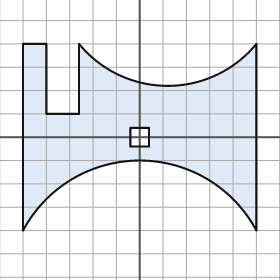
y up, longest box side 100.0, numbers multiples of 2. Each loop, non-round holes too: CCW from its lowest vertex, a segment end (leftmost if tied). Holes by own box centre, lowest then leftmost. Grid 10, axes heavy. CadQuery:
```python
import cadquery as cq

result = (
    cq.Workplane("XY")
    .moveTo(-50.0, -40.0)
    .threePointArc((0.0, -10.0), (50.0, -40.0))
    .lineTo(50.0, 40.0)
    .threePointArc((12.0, 22.0), (-26.0, 40.0))
    .lineTo(-26.0, 10.0)
    .lineTo(-40.0, 10.0)
    .lineTo(-40.0, 40.0)
    .lineTo(-50.0, 40.0)
    .close()
    .moveTo(-4.0, -4.0)
    .lineTo(4.0, -4.0)
    .lineTo(4.0, 4.0)
    .lineTo(-4.0, 4.0)
    .close()
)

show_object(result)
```